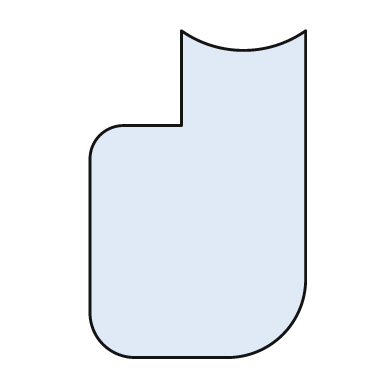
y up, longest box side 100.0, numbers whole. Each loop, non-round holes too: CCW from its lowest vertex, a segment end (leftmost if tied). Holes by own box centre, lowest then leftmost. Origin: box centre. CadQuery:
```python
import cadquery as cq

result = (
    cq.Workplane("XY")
    .moveTo(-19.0, -50.0)
    .lineTo(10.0, -50.0)
    .threePointArc((26.0, -43.0), (33.0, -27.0))
    .lineTo(33.0, 50.0)
    .threePointArc((14.0, 44.0), (-5.0, 50.0))
    .lineTo(-5.0, 21.0)
    .lineTo(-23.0, 21.0)
    .threePointArc((-30.0, 18.0), (-33.0, 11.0))
    .lineTo(-33.0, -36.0)
    .threePointArc((-29.0, -46.0), (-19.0, -50.0))
    .close()
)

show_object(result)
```